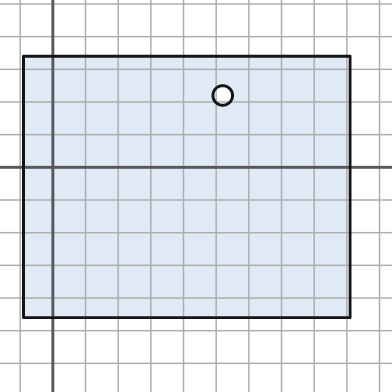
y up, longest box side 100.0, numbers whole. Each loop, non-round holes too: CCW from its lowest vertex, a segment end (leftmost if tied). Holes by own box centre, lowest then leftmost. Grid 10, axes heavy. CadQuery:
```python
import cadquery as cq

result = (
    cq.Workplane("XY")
    .moveTo(-9.0, -46.0)
    .lineTo(91.0, -46.0)
    .lineTo(91.0, 34.0)
    .lineTo(-9.0, 34.0)
    .close()
    .moveTo(52.0, 22.0)
    .circle(3.0)
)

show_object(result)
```